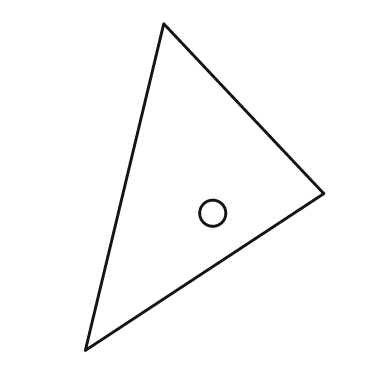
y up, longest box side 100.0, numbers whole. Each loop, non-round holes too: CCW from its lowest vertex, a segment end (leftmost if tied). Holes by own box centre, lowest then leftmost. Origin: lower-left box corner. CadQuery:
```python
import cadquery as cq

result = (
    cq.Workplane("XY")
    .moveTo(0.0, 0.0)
    .lineTo(73.0, 48.0)
    .lineTo(24.0, 100.0)
    .close()
    .moveTo(39.0, 42.0)
    .circle(4.0)
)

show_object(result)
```